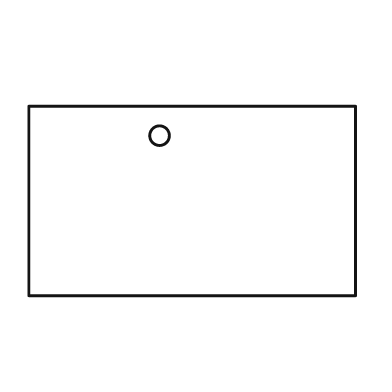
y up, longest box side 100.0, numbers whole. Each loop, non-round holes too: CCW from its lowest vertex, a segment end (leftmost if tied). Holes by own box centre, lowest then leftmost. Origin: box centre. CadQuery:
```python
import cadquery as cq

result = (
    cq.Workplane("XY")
    .moveTo(-50.0, -29.0)
    .lineTo(50.0, -29.0)
    .lineTo(50.0, 29.0)
    .lineTo(-50.0, 29.0)
    .close()
    .moveTo(-10.0, 20.0)
    .circle(3.0)
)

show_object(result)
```